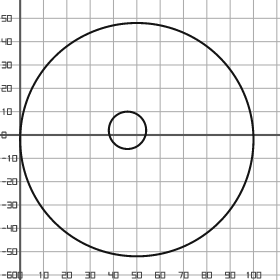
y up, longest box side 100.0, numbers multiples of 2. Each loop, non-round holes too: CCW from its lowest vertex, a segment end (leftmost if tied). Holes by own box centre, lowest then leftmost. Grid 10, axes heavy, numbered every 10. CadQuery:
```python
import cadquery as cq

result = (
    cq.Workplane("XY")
    .moveTo(50.0, -2.0)
    .circle(50.0)
    .moveTo(46.0, 2.0)
    .circle(8.0)
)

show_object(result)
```